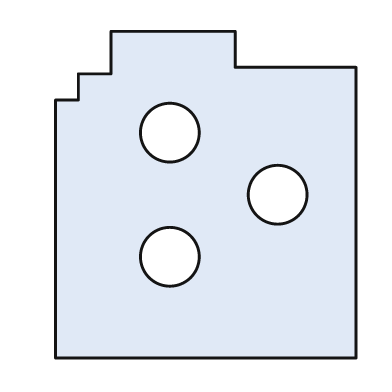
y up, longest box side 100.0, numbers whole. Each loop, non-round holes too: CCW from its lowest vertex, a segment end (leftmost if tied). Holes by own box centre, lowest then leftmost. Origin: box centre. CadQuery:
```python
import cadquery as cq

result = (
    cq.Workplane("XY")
    .moveTo(-46.0, -50.0)
    .lineTo(46.0, -50.0)
    .lineTo(46.0, 39.0)
    .lineTo(9.0, 39.0)
    .lineTo(9.0, 50.0)
    .lineTo(-29.0, 50.0)
    .lineTo(-29.0, 37.0)
    .lineTo(-39.0, 37.0)
    .lineTo(-39.0, 29.0)
    .lineTo(-46.0, 29.0)
    .close()
    .moveTo(-11.0, -19.0)
    .circle(9.0)
    .moveTo(22.0, 0.0)
    .circle(9.0)
    .moveTo(-11.0, 19.0)
    .circle(9.0)
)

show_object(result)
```